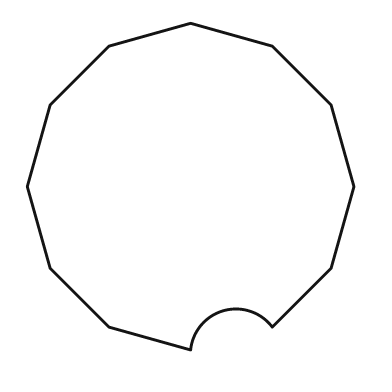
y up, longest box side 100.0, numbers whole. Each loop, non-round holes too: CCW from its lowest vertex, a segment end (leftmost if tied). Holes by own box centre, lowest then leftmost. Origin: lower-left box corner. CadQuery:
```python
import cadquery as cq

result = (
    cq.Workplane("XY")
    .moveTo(50.0, 0.0)
    .threePointArc((60.0, 12.0), (75.0, 7.0))
    .lineTo(93.0, 25.0)
    .lineTo(100.0, 50.0)
    .lineTo(93.0, 75.0)
    .lineTo(75.0, 93.0)
    .lineTo(50.0, 100.0)
    .lineTo(25.0, 93.0)
    .lineTo(7.0, 75.0)
    .lineTo(0.0, 50.0)
    .lineTo(7.0, 25.0)
    .lineTo(25.0, 7.0)
    .close()
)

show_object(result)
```